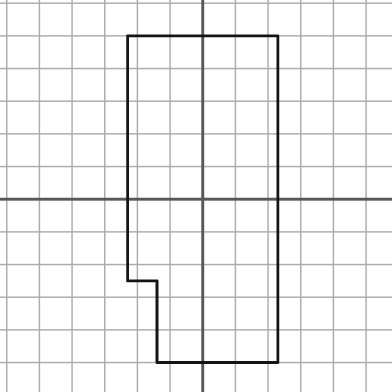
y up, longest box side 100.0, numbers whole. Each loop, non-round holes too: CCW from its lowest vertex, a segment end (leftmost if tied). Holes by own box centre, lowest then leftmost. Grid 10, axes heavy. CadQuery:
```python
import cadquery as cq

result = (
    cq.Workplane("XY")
    .moveTo(-14.0, -50.0)
    .lineTo(23.0, -50.0)
    .lineTo(23.0, 50.0)
    .lineTo(-23.0, 50.0)
    .lineTo(-23.0, -25.0)
    .lineTo(-14.0, -25.0)
    .close()
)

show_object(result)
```